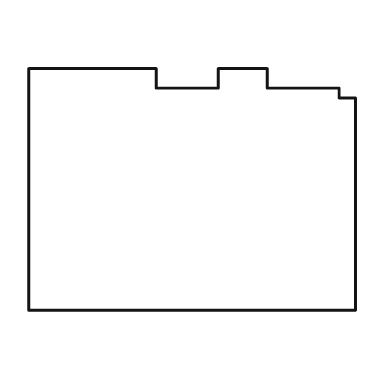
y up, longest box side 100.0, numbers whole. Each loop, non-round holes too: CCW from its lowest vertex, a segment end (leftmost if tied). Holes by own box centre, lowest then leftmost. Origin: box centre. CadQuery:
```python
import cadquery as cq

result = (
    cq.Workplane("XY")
    .moveTo(-50.0, -37.0)
    .lineTo(50.0, -37.0)
    .lineTo(50.0, 28.0)
    .lineTo(45.0, 28.0)
    .lineTo(45.0, 31.0)
    .lineTo(23.0, 31.0)
    .lineTo(23.0, 37.0)
    .lineTo(8.0, 37.0)
    .lineTo(8.0, 31.0)
    .lineTo(-11.0, 31.0)
    .lineTo(-11.0, 37.0)
    .lineTo(-50.0, 37.0)
    .close()
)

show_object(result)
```